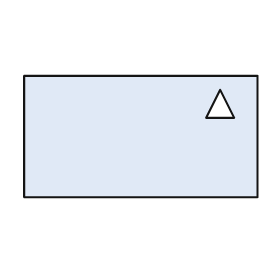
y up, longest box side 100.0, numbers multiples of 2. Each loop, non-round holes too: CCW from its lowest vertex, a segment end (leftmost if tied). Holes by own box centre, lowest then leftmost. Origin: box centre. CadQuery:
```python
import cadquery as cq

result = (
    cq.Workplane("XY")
    .moveTo(-50.0, -26.0)
    .lineTo(50.0, -26.0)
    .lineTo(50.0, 26.0)
    .lineTo(-50.0, 26.0)
    .close()
    .moveTo(28.0, 8.0)
    .lineTo(40.0, 8.0)
    .lineTo(34.0, 20.0)
    .close()
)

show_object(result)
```